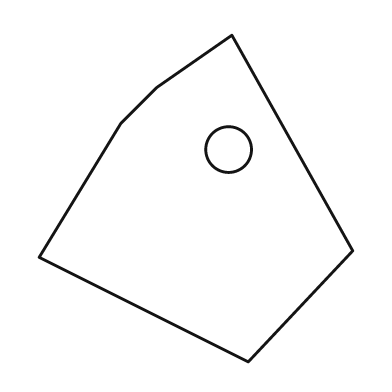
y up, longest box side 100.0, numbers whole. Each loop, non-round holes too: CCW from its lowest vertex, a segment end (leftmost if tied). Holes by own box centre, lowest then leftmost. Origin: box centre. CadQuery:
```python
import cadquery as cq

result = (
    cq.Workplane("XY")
    .moveTo(16.0, -50.0)
    .lineTo(48.0, -16.0)
    .lineTo(11.0, 50.0)
    .lineTo(-12.0, 34.0)
    .lineTo(-23.0, 23.0)
    .lineTo(-48.0, -18.0)
    .close()
    .moveTo(10.0, 15.0)
    .circle(7.0)
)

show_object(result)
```